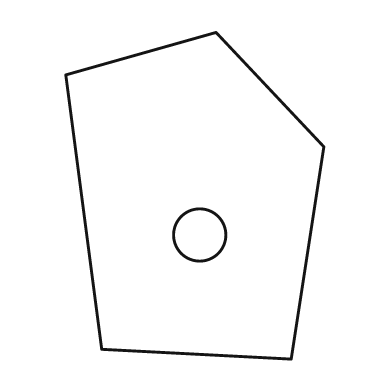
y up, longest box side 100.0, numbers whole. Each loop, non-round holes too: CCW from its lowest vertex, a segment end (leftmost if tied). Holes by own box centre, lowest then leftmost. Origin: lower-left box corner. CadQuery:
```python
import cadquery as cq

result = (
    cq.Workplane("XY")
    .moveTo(69.0, 0.0)
    .lineTo(79.0, 65.0)
    .lineTo(46.0, 100.0)
    .lineTo(0.0, 87.0)
    .lineTo(11.0, 3.0)
    .close()
    .moveTo(41.0, 38.0)
    .circle(8.0)
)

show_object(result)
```